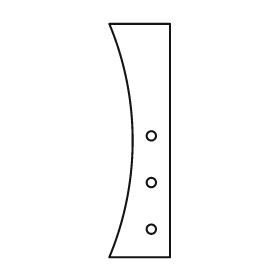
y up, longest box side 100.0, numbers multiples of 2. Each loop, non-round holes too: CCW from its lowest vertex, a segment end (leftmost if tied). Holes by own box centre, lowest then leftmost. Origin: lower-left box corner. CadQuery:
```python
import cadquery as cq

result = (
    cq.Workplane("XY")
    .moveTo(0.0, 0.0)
    .lineTo(26.0, 0.0)
    .lineTo(26.0, 100.0)
    .lineTo(0.0, 100.0)
    .threePointArc((10.0, 50.0), (0.0, 0.0))
    .close()
    .moveTo(18.0, 12.0)
    .circle(2.0)
    .moveTo(18.0, 32.0)
    .circle(2.0)
    .moveTo(18.0, 52.0)
    .circle(2.0)
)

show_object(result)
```